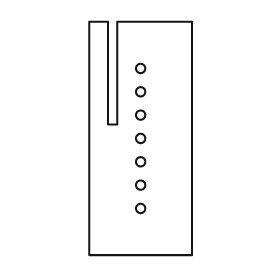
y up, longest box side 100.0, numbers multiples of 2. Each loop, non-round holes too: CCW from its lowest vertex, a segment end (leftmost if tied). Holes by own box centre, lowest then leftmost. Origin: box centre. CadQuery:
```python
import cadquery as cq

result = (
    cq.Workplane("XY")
    .moveTo(-22.0, -50.0)
    .lineTo(22.0, -50.0)
    .lineTo(22.0, 50.0)
    .lineTo(-10.0, 50.0)
    .lineTo(-10.0, 6.0)
    .lineTo(-14.0, 6.0)
    .lineTo(-14.0, 50.0)
    .lineTo(-22.0, 50.0)
    .close()
    .moveTo(0.0, -30.0)
    .circle(2.0)
    .moveTo(0.0, -20.0)
    .circle(2.0)
    .moveTo(0.0, -10.0)
    .circle(2.0)
    .moveTo(0.0, 0.0)
    .circle(2.0)
    .moveTo(0.0, 10.0)
    .circle(2.0)
    .moveTo(0.0, 20.0)
    .circle(2.0)
    .moveTo(0.0, 30.0)
    .circle(2.0)
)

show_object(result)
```